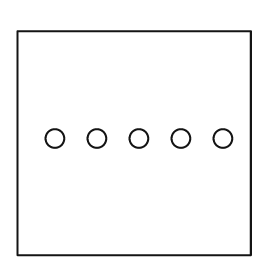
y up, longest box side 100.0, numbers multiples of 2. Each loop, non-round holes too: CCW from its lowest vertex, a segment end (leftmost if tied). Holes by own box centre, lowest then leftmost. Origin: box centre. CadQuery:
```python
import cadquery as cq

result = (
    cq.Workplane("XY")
    .moveTo(-50.0, -48.0)
    .lineTo(50.0, -48.0)
    .lineTo(50.0, 48.0)
    .lineTo(-50.0, 48.0)
    .close()
    .moveTo(-34.0, 2.0)
    .circle(4.0)
    .moveTo(-16.0, 2.0)
    .circle(4.0)
    .moveTo(2.0, 2.0)
    .circle(4.0)
    .moveTo(20.0, 2.0)
    .circle(4.0)
    .moveTo(38.0, 2.0)
    .circle(4.0)
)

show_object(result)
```